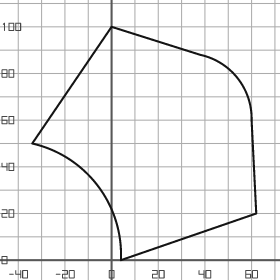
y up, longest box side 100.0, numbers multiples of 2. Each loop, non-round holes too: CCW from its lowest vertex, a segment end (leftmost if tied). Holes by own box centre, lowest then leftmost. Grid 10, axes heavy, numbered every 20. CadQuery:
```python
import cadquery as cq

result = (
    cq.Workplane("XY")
    .moveTo(4.0, 0.0)
    .lineTo(62.0, 20.0)
    .lineTo(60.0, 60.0)
    .threePointArc((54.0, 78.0), (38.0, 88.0))
    .lineTo(0.0, 100.0)
    .lineTo(-34.0, 50.0)
    .threePointArc((-6.0, 32.0), (4.0, 0.0))
    .close()
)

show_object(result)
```